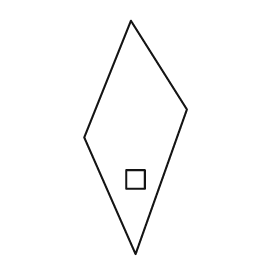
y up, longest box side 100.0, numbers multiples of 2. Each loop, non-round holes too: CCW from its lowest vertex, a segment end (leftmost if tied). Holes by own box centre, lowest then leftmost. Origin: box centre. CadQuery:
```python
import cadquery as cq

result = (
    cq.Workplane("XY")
    .moveTo(0.0, -50.0)
    .lineTo(22.0, 12.0)
    .lineTo(-2.0, 50.0)
    .lineTo(-22.0, 0.0)
    .close()
    .moveTo(-4.0, -22.0)
    .lineTo(4.0, -22.0)
    .lineTo(4.0, -14.0)
    .lineTo(-4.0, -14.0)
    .close()
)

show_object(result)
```